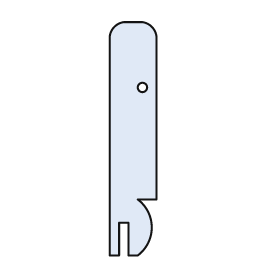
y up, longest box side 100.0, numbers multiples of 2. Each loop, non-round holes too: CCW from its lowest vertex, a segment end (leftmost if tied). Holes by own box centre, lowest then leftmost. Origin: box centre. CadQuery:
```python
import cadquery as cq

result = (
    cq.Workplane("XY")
    .moveTo(-10.0, -50.0)
    .lineTo(-6.0, -50.0)
    .lineTo(-6.0, -36.0)
    .lineTo(-2.0, -36.0)
    .lineTo(-2.0, -50.0)
    .lineTo(2.0, -50.0)
    .threePointArc((8.0, -38.0), (2.0, -26.0))
    .lineTo(10.0, -26.0)
    .lineTo(10.0, 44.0)
    .threePointArc((8.0, 48.0), (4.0, 50.0))
    .lineTo(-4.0, 50.0)
    .threePointArc((-8.0, 48.0), (-10.0, 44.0))
    .close()
    .moveTo(4.0, 22.0)
    .circle(2.0)
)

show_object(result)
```